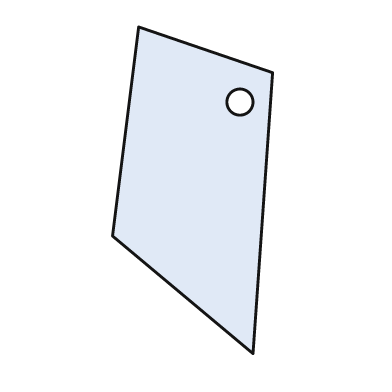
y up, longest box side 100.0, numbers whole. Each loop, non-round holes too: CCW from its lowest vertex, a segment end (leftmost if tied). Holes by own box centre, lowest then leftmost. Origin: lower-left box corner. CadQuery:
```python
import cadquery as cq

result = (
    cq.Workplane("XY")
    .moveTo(43.0, 0.0)
    .lineTo(49.0, 86.0)
    .lineTo(8.0, 100.0)
    .lineTo(0.0, 36.0)
    .close()
    .moveTo(39.0, 77.0)
    .circle(4.0)
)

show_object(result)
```